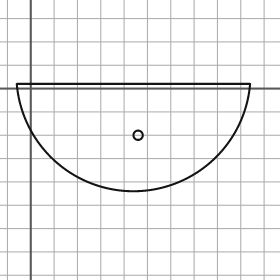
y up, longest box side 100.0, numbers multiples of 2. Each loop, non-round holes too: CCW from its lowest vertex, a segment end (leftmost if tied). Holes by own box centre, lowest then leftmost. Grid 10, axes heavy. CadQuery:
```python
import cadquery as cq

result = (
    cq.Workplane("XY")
    .moveTo(-6.0, 2.0)
    .threePointArc((44.0, -44.0), (94.0, 2.0))
    .close()
    .moveTo(46.0, -20.0)
    .circle(2.0)
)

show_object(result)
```